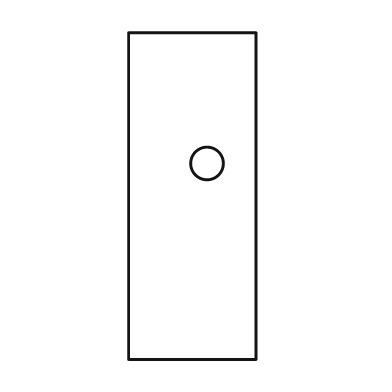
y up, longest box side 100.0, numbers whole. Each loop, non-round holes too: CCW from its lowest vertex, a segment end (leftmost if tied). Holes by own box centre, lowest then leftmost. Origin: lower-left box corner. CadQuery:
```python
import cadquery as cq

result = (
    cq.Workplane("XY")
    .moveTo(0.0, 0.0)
    .lineTo(39.0, 0.0)
    .lineTo(39.0, 100.0)
    .lineTo(0.0, 100.0)
    .close()
    .moveTo(24.0, 60.0)
    .circle(5.0)
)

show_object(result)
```